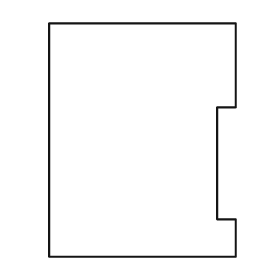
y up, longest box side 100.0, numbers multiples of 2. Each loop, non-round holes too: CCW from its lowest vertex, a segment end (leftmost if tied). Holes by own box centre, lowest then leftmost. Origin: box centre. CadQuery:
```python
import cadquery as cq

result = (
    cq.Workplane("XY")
    .moveTo(-40.0, -50.0)
    .lineTo(40.0, -50.0)
    .lineTo(40.0, -34.0)
    .lineTo(32.0, -34.0)
    .lineTo(32.0, 14.0)
    .lineTo(40.0, 14.0)
    .lineTo(40.0, 50.0)
    .lineTo(-40.0, 50.0)
    .close()
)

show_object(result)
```